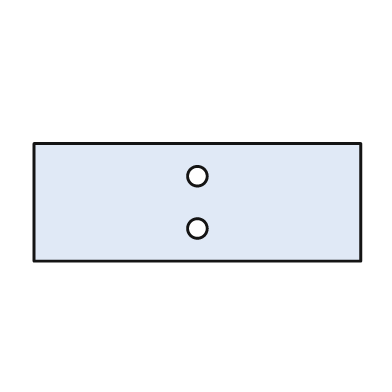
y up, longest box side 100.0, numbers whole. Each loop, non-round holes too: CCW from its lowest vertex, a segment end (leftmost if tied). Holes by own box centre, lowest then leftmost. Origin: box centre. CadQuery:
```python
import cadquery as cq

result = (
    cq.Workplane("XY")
    .moveTo(-50.0, -18.0)
    .lineTo(50.0, -18.0)
    .lineTo(50.0, 18.0)
    .lineTo(-50.0, 18.0)
    .close()
    .moveTo(0.0, -8.0)
    .circle(3.0)
    .moveTo(0.0, 8.0)
    .circle(3.0)
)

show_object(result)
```